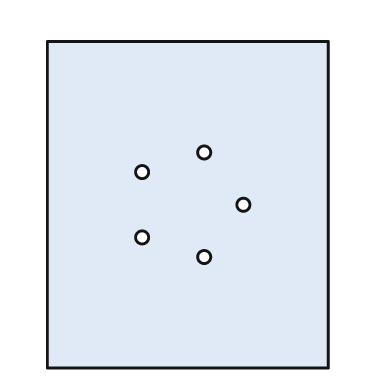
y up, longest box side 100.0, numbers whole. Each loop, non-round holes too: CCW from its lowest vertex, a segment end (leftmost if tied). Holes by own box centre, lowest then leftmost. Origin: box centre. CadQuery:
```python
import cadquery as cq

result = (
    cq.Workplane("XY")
    .moveTo(-43.0, -50.0)
    .lineTo(43.0, -50.0)
    .lineTo(43.0, 50.0)
    .lineTo(-43.0, 50.0)
    .close()
    .moveTo(5.0, -16.0)
    .circle(2.0)
    .moveTo(-14.0, -10.0)
    .circle(2.0)
    .moveTo(17.0, 0.0)
    .circle(2.0)
    .moveTo(-14.0, 10.0)
    .circle(2.0)
    .moveTo(5.0, 16.0)
    .circle(2.0)
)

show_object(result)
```